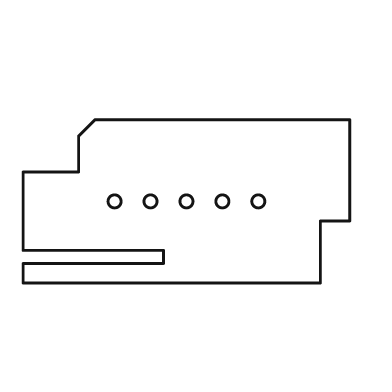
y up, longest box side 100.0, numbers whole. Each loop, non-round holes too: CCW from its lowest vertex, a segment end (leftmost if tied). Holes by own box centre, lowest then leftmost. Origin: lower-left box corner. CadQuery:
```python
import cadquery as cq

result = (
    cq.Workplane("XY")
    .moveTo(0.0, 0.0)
    .lineTo(91.0, 0.0)
    .lineTo(91.0, 19.0)
    .lineTo(100.0, 19.0)
    .lineTo(100.0, 50.0)
    .lineTo(22.0, 50.0)
    .lineTo(17.0, 45.0)
    .lineTo(17.0, 34.0)
    .lineTo(0.0, 34.0)
    .lineTo(0.0, 10.0)
    .lineTo(43.0, 10.0)
    .lineTo(43.0, 6.0)
    .lineTo(0.0, 6.0)
    .close()
    .moveTo(28.0, 25.0)
    .circle(2.0)
    .moveTo(39.0, 25.0)
    .circle(2.0)
    .moveTo(50.0, 25.0)
    .circle(2.0)
    .moveTo(61.0, 25.0)
    .circle(2.0)
    .moveTo(72.0, 25.0)
    .circle(2.0)
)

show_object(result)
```